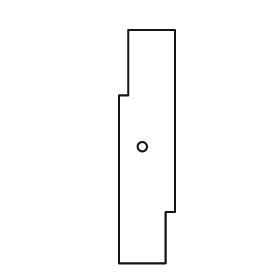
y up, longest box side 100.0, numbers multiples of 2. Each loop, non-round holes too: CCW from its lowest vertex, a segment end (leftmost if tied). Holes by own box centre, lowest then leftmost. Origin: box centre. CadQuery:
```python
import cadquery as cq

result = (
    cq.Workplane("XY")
    .moveTo(-12.0, -50.0)
    .lineTo(8.0, -50.0)
    .lineTo(8.0, -28.0)
    .lineTo(12.0, -28.0)
    .lineTo(12.0, 50.0)
    .lineTo(-8.0, 50.0)
    .lineTo(-8.0, 22.0)
    .lineTo(-12.0, 22.0)
    .close()
    .moveTo(-2.0, 0.0)
    .circle(2.0)
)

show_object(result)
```